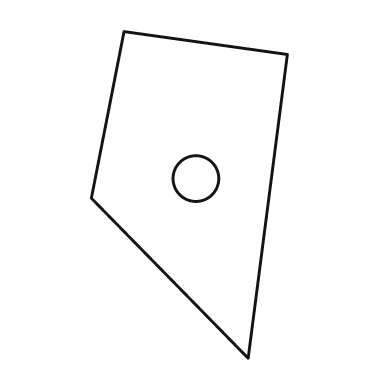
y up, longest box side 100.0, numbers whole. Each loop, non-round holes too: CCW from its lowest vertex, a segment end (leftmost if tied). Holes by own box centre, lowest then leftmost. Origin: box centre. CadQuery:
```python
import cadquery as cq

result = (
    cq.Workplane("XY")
    .moveTo(18.0, -50.0)
    .lineTo(30.0, 43.0)
    .lineTo(-20.0, 50.0)
    .lineTo(-30.0, -1.0)
    .close()
    .moveTo(2.0, 5.0)
    .circle(7.0)
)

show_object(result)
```